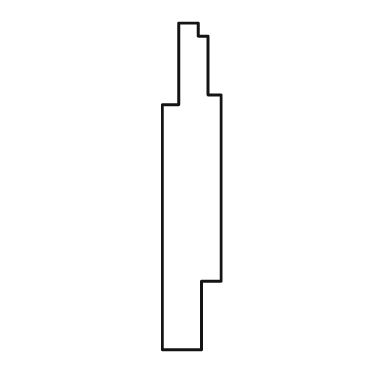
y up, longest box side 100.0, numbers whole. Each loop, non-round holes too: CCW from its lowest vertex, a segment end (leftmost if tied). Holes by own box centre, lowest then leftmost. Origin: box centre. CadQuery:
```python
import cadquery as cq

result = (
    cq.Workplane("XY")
    .moveTo(-9.0, -50.0)
    .lineTo(3.0, -50.0)
    .lineTo(3.0, -29.0)
    .lineTo(9.0, -29.0)
    .lineTo(9.0, 28.0)
    .lineTo(5.0, 28.0)
    .lineTo(5.0, 46.0)
    .lineTo(2.0, 46.0)
    .lineTo(2.0, 50.0)
    .lineTo(-4.0, 50.0)
    .lineTo(-4.0, 25.0)
    .lineTo(-9.0, 25.0)
    .close()
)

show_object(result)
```